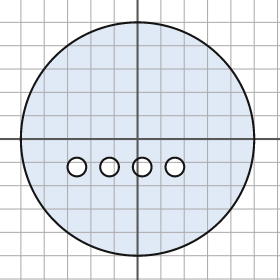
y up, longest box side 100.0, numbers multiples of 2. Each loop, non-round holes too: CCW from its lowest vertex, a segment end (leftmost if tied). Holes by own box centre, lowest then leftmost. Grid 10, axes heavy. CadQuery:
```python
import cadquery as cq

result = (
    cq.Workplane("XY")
    .moveTo(0.0, 0.0)
    .circle(50.0)
    .moveTo(-26.0, -12.0)
    .circle(4.0)
    .moveTo(-12.0, -12.0)
    .circle(4.0)
    .moveTo(2.0, -12.0)
    .circle(4.0)
    .moveTo(16.0, -12.0)
    .circle(4.0)
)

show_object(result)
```